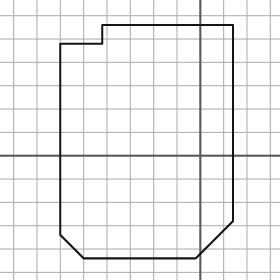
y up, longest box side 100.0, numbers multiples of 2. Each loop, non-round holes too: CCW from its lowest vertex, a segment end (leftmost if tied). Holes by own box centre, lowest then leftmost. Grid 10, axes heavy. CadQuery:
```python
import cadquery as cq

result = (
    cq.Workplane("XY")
    .moveTo(-50.0, -44.0)
    .lineTo(-2.0, -44.0)
    .lineTo(14.0, -28.0)
    .lineTo(14.0, 56.0)
    .lineTo(-42.0, 56.0)
    .lineTo(-42.0, 48.0)
    .lineTo(-60.0, 48.0)
    .lineTo(-60.0, -34.0)
    .close()
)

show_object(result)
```